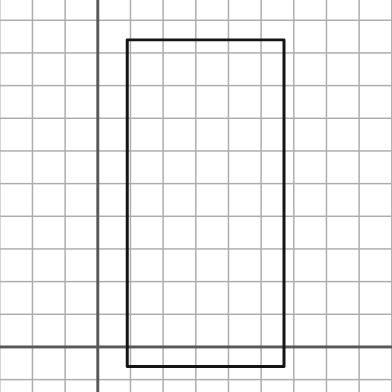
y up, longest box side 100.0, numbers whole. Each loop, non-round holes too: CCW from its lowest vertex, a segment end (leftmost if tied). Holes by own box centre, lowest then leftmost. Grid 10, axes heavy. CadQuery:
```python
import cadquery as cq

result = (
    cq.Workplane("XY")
    .moveTo(9.0, -6.0)
    .lineTo(57.0, -6.0)
    .lineTo(57.0, 94.0)
    .lineTo(9.0, 94.0)
    .close()
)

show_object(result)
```